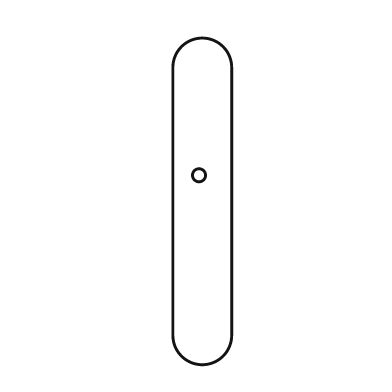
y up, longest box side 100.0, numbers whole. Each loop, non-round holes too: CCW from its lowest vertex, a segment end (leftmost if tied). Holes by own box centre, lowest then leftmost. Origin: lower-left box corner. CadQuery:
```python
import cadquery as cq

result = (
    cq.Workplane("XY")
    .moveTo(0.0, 9.0)
    .threePointArc((9.0, 0.0), (18.0, 9.0))
    .lineTo(18.0, 91.0)
    .threePointArc((9.0, 100.0), (0.0, 91.0))
    .close()
    .moveTo(8.0, 58.0)
    .circle(2.0)
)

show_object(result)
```